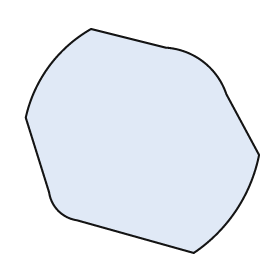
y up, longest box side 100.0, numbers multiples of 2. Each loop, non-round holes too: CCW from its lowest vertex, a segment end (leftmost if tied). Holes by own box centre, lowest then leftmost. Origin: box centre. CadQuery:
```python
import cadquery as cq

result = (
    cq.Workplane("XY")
    .moveTo(22.0, -48.0)
    .threePointArc((40.0, -30.0), (50.0, -6.0))
    .lineTo(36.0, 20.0)
    .threePointArc((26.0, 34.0), (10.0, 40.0))
    .lineTo(-22.0, 48.0)
    .threePointArc((-40.0, 32.0), (-50.0, 10.0))
    .lineTo(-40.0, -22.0)
    .threePointArc((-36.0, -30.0), (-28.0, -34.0))
    .close()
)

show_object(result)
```